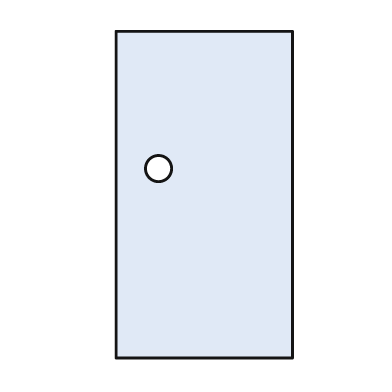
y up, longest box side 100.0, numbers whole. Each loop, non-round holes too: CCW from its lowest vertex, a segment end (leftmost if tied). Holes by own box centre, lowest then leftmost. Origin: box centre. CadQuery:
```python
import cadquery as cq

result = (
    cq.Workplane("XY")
    .moveTo(-27.0, -50.0)
    .lineTo(27.0, -50.0)
    .lineTo(27.0, 50.0)
    .lineTo(-27.0, 50.0)
    .close()
    .moveTo(-14.0, 8.0)
    .circle(4.0)
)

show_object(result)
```